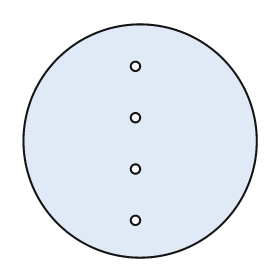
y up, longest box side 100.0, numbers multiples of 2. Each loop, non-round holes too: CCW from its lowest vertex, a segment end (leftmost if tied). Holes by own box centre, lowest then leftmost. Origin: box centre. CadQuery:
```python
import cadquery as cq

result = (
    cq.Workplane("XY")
    .moveTo(0.0, 0.0)
    .circle(50.0)
    .moveTo(-2.0, -34.0)
    .circle(2.0)
    .moveTo(-2.0, -12.0)
    .circle(2.0)
    .moveTo(-2.0, 10.0)
    .circle(2.0)
    .moveTo(-2.0, 32.0)
    .circle(2.0)
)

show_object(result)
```